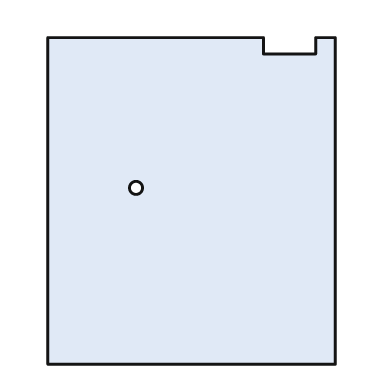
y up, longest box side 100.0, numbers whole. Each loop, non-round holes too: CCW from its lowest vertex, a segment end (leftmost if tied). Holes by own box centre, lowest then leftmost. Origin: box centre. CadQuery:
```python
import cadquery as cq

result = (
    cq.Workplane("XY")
    .moveTo(-44.0, -50.0)
    .lineTo(44.0, -50.0)
    .lineTo(44.0, 50.0)
    .lineTo(38.0, 50.0)
    .lineTo(38.0, 45.0)
    .lineTo(22.0, 45.0)
    .lineTo(22.0, 50.0)
    .lineTo(-44.0, 50.0)
    .close()
    .moveTo(-17.0, 4.0)
    .circle(2.0)
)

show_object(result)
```